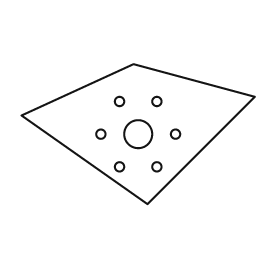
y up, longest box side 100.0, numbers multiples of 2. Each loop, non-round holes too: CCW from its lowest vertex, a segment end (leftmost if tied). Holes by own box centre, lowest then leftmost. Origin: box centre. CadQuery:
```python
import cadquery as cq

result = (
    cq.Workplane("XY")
    .moveTo(4.0, -30.0)
    .lineTo(50.0, 16.0)
    .lineTo(-2.0, 30.0)
    .lineTo(-50.0, 8.0)
    .close()
    .moveTo(-8.0, -14.0)
    .circle(2.0)
    .moveTo(8.0, -14.0)
    .circle(2.0)
    .moveTo(-16.0, 0.0)
    .circle(2.0)
    .moveTo(0.0, 0.0)
    .circle(6.0)
    .moveTo(16.0, 0.0)
    .circle(2.0)
    .moveTo(-8.0, 14.0)
    .circle(2.0)
    .moveTo(8.0, 14.0)
    .circle(2.0)
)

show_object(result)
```